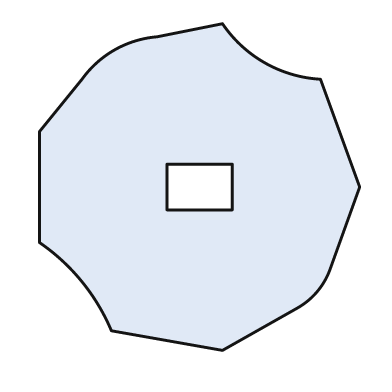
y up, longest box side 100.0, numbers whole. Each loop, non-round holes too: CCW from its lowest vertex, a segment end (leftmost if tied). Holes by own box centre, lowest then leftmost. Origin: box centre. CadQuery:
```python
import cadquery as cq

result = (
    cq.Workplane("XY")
    .moveTo(7.0, -50.0)
    .lineTo(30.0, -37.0)
    .threePointArc((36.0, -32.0), (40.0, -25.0))
    .lineTo(49.0, 0.0)
    .lineTo(37.0, 33.0)
    .threePointArc((20.0, 38.0), (7.0, 50.0))
    .lineTo(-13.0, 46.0)
    .threePointArc((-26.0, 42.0), (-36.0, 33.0))
    .lineTo(-49.0, 17.0)
    .lineTo(-49.0, -17.0)
    .threePointArc((-36.0, -29.0), (-27.0, -44.0))
    .close()
    .moveTo(-10.0, -7.0)
    .lineTo(10.0, -7.0)
    .lineTo(10.0, 7.0)
    .lineTo(-10.0, 7.0)
    .close()
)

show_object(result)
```